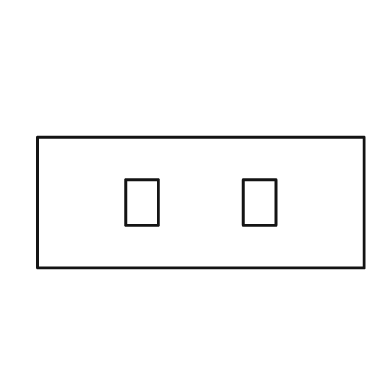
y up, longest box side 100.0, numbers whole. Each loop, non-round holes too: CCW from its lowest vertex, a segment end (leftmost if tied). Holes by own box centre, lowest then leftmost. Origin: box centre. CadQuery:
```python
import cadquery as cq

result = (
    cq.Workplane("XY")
    .moveTo(-50.0, -20.0)
    .lineTo(50.0, -20.0)
    .lineTo(50.0, 20.0)
    .lineTo(-50.0, 20.0)
    .close()
    .moveTo(-23.0, -7.0)
    .lineTo(-13.0, -7.0)
    .lineTo(-13.0, 7.0)
    .lineTo(-23.0, 7.0)
    .close()
    .moveTo(13.0, -7.0)
    .lineTo(23.0, -7.0)
    .lineTo(23.0, 7.0)
    .lineTo(13.0, 7.0)
    .close()
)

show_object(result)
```